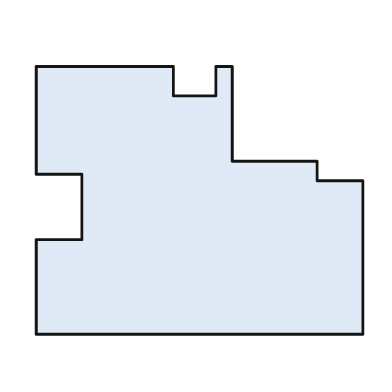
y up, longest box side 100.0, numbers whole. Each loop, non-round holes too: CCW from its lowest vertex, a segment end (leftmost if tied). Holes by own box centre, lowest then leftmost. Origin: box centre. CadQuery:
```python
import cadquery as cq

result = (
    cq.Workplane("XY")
    .moveTo(-50.0, -41.0)
    .lineTo(50.0, -41.0)
    .lineTo(50.0, 6.0)
    .lineTo(36.0, 6.0)
    .lineTo(36.0, 12.0)
    .lineTo(10.0, 12.0)
    .lineTo(10.0, 41.0)
    .lineTo(5.0, 41.0)
    .lineTo(5.0, 32.0)
    .lineTo(-8.0, 32.0)
    .lineTo(-8.0, 41.0)
    .lineTo(-50.0, 41.0)
    .lineTo(-50.0, 8.0)
    .lineTo(-36.0, 8.0)
    .lineTo(-36.0, -12.0)
    .lineTo(-50.0, -12.0)
    .close()
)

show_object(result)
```